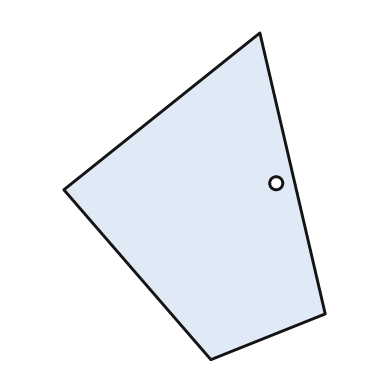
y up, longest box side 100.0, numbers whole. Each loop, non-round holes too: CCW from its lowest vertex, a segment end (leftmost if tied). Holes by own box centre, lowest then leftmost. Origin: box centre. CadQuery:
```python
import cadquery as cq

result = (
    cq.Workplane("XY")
    .moveTo(5.0, -50.0)
    .lineTo(40.0, -36.0)
    .lineTo(20.0, 50.0)
    .lineTo(-40.0, 2.0)
    .close()
    .moveTo(25.0, 4.0)
    .circle(2.0)
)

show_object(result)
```